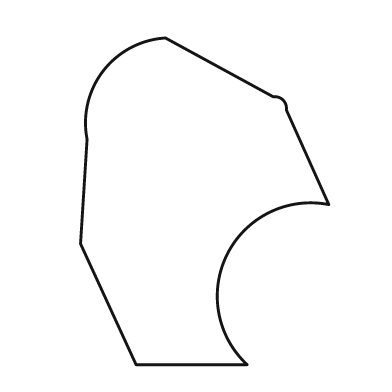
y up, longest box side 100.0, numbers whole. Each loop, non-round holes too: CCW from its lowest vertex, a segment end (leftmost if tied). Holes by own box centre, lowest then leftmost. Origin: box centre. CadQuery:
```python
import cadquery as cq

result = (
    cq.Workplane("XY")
    .moveTo(-21.0, -50.0)
    .lineTo(13.0, -50.0)
    .threePointArc((7.0, -16.0), (38.0, -1.0))
    .lineTo(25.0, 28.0)
    .threePointArc((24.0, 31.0), (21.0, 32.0))
    .lineTo(-12.0, 50.0)
    .threePointArc((-31.0, 40.0), (-36.0, 19.0))
    .lineTo(-38.0, -13.0)
    .close()
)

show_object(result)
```